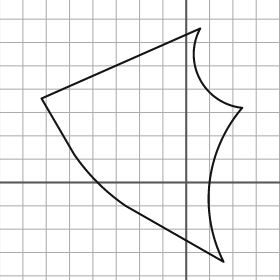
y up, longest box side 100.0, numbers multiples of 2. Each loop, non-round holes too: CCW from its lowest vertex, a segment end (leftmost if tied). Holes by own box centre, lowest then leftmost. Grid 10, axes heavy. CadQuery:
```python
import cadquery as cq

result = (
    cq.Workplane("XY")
    .moveTo(16.0, -34.0)
    .threePointArc((10.0, 0.0), (24.0, 32.0))
    .threePointArc((6.0, 44.0), (6.0, 66.0))
    .lineTo(-62.0, 36.0)
    .lineTo(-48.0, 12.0)
    .threePointArc((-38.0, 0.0), (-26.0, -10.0))
    .close()
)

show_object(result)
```